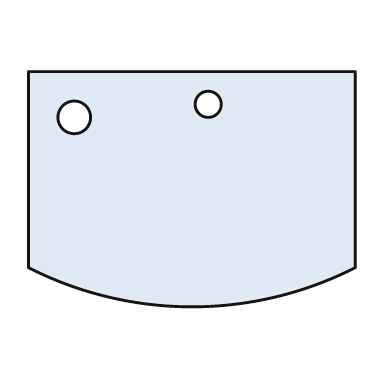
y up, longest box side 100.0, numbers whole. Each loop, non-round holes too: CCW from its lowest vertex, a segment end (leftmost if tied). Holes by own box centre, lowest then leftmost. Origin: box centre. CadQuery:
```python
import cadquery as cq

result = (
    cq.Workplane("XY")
    .moveTo(-50.0, -24.0)
    .threePointArc((0.0, -36.0), (50.0, -24.0))
    .lineTo(50.0, 36.0)
    .lineTo(-50.0, 36.0)
    .close()
    .moveTo(-36.0, 22.0)
    .circle(5.0)
    .moveTo(5.0, 26.0)
    .circle(4.0)
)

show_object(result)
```